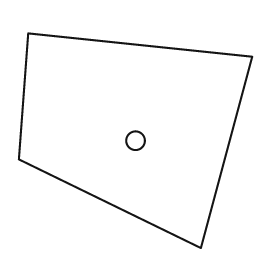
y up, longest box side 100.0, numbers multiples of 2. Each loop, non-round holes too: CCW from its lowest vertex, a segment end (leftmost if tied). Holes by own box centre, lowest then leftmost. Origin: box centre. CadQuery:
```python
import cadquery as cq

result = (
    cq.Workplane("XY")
    .moveTo(28.0, -46.0)
    .lineTo(50.0, 36.0)
    .lineTo(-46.0, 46.0)
    .lineTo(-50.0, -8.0)
    .close()
    .moveTo(0.0, 0.0)
    .circle(4.0)
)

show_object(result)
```